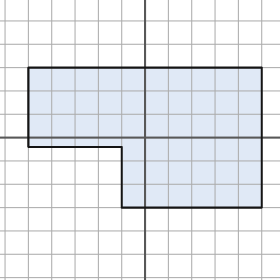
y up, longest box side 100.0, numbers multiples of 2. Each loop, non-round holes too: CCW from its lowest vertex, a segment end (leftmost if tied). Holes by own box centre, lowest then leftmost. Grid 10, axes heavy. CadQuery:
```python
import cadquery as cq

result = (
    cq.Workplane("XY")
    .moveTo(-10.0, -30.0)
    .lineTo(50.0, -30.0)
    .lineTo(50.0, 30.0)
    .lineTo(-50.0, 30.0)
    .lineTo(-50.0, -4.0)
    .lineTo(-10.0, -4.0)
    .close()
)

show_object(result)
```